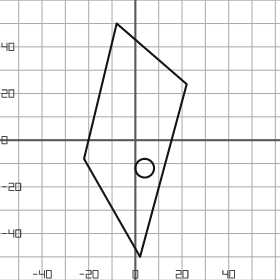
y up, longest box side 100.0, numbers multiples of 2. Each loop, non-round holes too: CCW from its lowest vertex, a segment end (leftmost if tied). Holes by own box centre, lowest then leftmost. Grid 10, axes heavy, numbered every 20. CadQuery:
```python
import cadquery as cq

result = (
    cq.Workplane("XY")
    .moveTo(2.0, -50.0)
    .lineTo(22.0, 24.0)
    .lineTo(-8.0, 50.0)
    .lineTo(-22.0, -8.0)
    .close()
    .moveTo(4.0, -12.0)
    .circle(4.0)
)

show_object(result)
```